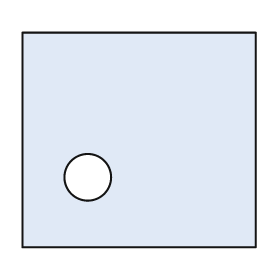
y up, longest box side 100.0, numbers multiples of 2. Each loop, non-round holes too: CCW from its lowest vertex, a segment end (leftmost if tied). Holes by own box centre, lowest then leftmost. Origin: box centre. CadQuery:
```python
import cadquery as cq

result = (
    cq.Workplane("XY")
    .moveTo(-50.0, -46.0)
    .lineTo(50.0, -46.0)
    .lineTo(50.0, 46.0)
    .lineTo(-50.0, 46.0)
    .close()
    .moveTo(-22.0, -16.0)
    .circle(10.0)
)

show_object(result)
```